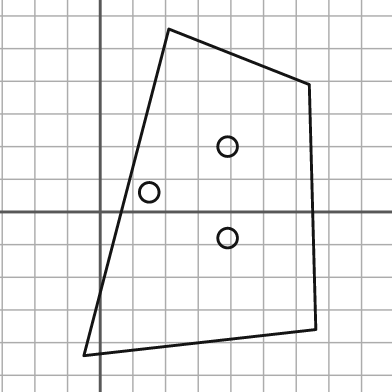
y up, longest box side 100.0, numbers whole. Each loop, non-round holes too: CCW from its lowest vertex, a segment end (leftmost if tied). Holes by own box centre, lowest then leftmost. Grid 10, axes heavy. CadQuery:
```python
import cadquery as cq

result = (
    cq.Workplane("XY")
    .moveTo(-5.0, -44.0)
    .lineTo(66.0, -36.0)
    .lineTo(64.0, 39.0)
    .lineTo(21.0, 56.0)
    .close()
    .moveTo(39.0, -8.0)
    .circle(3.0)
    .moveTo(15.0, 6.0)
    .circle(3.0)
    .moveTo(39.0, 20.0)
    .circle(3.0)
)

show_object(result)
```